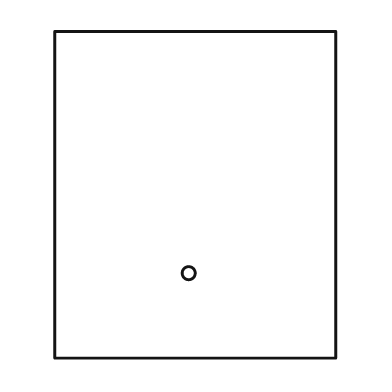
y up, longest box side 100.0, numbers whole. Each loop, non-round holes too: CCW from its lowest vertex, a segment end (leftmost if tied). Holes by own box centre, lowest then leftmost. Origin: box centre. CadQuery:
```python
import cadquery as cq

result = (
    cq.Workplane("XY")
    .moveTo(-43.0, -50.0)
    .lineTo(43.0, -50.0)
    .lineTo(43.0, 50.0)
    .lineTo(-43.0, 50.0)
    .close()
    .moveTo(-2.0, -24.0)
    .circle(2.0)
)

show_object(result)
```